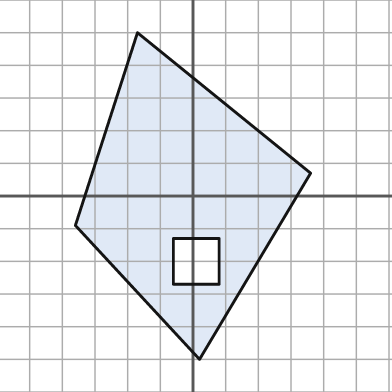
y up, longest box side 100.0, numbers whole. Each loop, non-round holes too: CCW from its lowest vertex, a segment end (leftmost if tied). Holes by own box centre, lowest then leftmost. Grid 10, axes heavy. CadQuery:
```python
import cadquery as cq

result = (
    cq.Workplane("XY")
    .moveTo(2.0, -50.0)
    .lineTo(36.0, 7.0)
    .lineTo(-17.0, 50.0)
    .lineTo(-36.0, -9.0)
    .close()
    .moveTo(-6.0, -27.0)
    .lineTo(8.0, -27.0)
    .lineTo(8.0, -13.0)
    .lineTo(-6.0, -13.0)
    .close()
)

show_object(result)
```